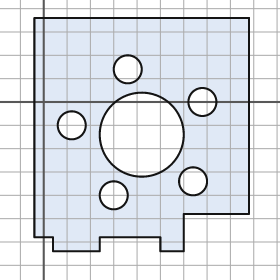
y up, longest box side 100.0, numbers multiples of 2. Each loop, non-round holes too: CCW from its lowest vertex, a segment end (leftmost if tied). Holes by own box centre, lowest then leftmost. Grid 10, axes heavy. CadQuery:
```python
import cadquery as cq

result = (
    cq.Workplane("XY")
    .moveTo(4.0, -64.0)
    .lineTo(24.0, -64.0)
    .lineTo(24.0, -58.0)
    .lineTo(50.0, -58.0)
    .lineTo(50.0, -64.0)
    .lineTo(60.0, -64.0)
    .lineTo(60.0, -48.0)
    .lineTo(88.0, -48.0)
    .lineTo(88.0, 36.0)
    .lineTo(-4.0, 36.0)
    .lineTo(-4.0, -58.0)
    .lineTo(4.0, -58.0)
    .close()
    .moveTo(30.0, -40.0)
    .circle(6.0)
    .moveTo(64.0, -34.0)
    .circle(6.0)
    .moveTo(42.0, -14.0)
    .circle(18.0)
    .moveTo(12.0, -10.0)
    .circle(6.0)
    .moveTo(68.0, 0.0)
    .circle(6.0)
    .moveTo(36.0, 14.0)
    .circle(6.0)
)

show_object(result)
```